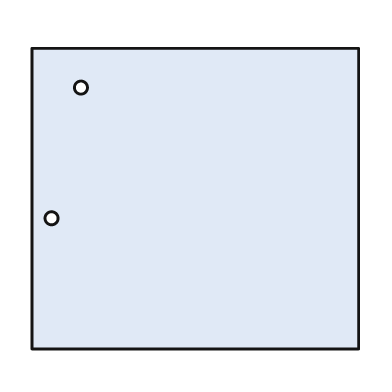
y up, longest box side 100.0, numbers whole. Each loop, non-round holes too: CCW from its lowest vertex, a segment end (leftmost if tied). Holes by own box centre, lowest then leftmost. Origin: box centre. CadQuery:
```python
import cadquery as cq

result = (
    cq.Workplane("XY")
    .moveTo(-50.0, -46.0)
    .lineTo(50.0, -46.0)
    .lineTo(50.0, 46.0)
    .lineTo(-50.0, 46.0)
    .close()
    .moveTo(-44.0, -6.0)
    .circle(2.0)
    .moveTo(-35.0, 34.0)
    .circle(2.0)
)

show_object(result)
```